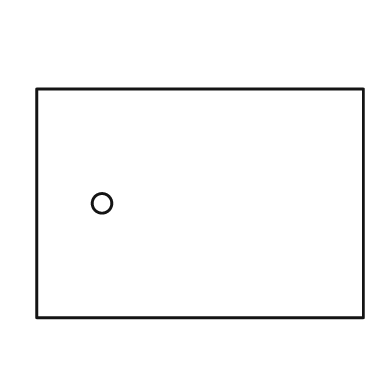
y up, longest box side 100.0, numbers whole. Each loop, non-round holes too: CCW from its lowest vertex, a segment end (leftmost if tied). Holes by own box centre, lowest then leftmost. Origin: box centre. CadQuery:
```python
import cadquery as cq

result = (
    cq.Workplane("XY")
    .moveTo(-50.0, -35.0)
    .lineTo(50.0, -35.0)
    .lineTo(50.0, 35.0)
    .lineTo(-50.0, 35.0)
    .close()
    .moveTo(-30.0, 0.0)
    .circle(3.0)
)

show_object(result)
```